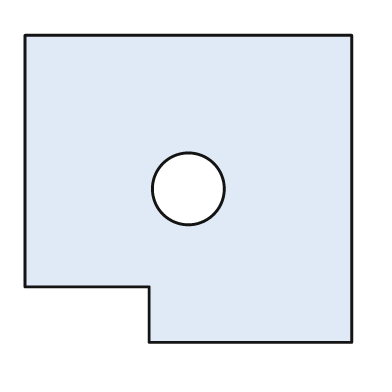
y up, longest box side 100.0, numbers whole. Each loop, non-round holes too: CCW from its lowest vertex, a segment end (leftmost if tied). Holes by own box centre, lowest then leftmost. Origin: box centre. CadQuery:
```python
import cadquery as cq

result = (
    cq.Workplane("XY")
    .moveTo(-12.0, -47.0)
    .lineTo(50.0, -47.0)
    .lineTo(50.0, 47.0)
    .lineTo(-50.0, 47.0)
    .lineTo(-50.0, -30.0)
    .lineTo(-12.0, -30.0)
    .close()
    .moveTo(0.0, 0.0)
    .circle(11.0)
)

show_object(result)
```